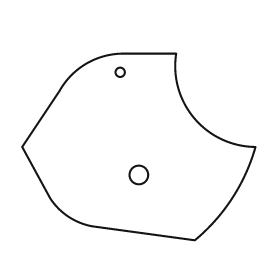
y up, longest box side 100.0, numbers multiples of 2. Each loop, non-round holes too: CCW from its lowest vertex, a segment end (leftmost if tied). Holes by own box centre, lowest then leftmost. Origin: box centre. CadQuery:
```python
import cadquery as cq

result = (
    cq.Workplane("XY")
    .moveTo(24.0, -40.0)
    .threePointArc((40.0, -22.0), (50.0, 0.0))
    .threePointArc((24.0, 12.0), (16.0, 40.0))
    .lineTo(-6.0, 40.0)
    .threePointArc((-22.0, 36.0), (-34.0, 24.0))
    .lineTo(-50.0, 0.0)
    .lineTo(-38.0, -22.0)
    .threePointArc((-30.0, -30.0), (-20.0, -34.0))
    .close()
    .moveTo(0.0, -12.0)
    .circle(4.0)
    .moveTo(-8.0, 32.0)
    .circle(2.0)
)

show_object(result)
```